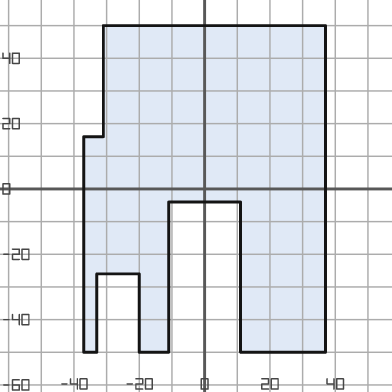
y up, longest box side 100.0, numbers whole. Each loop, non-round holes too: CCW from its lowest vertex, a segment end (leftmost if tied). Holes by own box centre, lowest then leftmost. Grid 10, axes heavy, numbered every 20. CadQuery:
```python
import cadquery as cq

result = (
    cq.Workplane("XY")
    .moveTo(-37.0, -50.0)
    .lineTo(-33.0, -50.0)
    .lineTo(-33.0, -26.0)
    .lineTo(-20.0, -26.0)
    .lineTo(-20.0, -50.0)
    .lineTo(-11.0, -50.0)
    .lineTo(-11.0, -4.0)
    .lineTo(11.0, -4.0)
    .lineTo(11.0, -50.0)
    .lineTo(37.0, -50.0)
    .lineTo(37.0, 50.0)
    .lineTo(-31.0, 50.0)
    .lineTo(-31.0, 16.0)
    .lineTo(-37.0, 16.0)
    .close()
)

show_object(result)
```